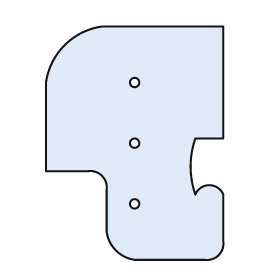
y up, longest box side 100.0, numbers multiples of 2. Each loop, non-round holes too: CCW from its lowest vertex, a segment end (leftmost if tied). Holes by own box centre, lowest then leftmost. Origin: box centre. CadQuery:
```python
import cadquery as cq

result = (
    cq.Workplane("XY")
    .moveTo(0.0, -50.0)
    .lineTo(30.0, -50.0)
    .threePointArc((36.0, -48.0), (38.0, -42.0))
    .lineTo(38.0, -22.0)
    .threePointArc((32.0, -18.0), (26.0, -22.0))
    .threePointArc((24.0, -10.0), (26.0, 2.0))
    .lineTo(38.0, 2.0)
    .lineTo(38.0, 50.0)
    .lineTo(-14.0, 50.0)
    .threePointArc((-30.0, 42.0), (-38.0, 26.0))
    .lineTo(-38.0, -12.0)
    .lineTo(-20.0, -12.0)
    .threePointArc((-14.0, -14.0), (-12.0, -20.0))
    .lineTo(-12.0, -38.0)
    .threePointArc((-8.0, -46.0), (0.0, -50.0))
    .close()
    .moveTo(0.0, -26.0)
    .circle(2.0)
    .moveTo(0.0, 0.0)
    .circle(2.0)
    .moveTo(0.0, 26.0)
    .circle(2.0)
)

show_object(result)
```